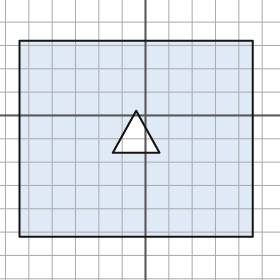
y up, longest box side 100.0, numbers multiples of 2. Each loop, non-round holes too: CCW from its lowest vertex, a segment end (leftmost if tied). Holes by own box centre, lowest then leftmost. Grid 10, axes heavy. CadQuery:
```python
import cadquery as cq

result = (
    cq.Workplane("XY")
    .moveTo(-54.0, -52.0)
    .lineTo(46.0, -52.0)
    .lineTo(46.0, 32.0)
    .lineTo(-54.0, 32.0)
    .close()
    .moveTo(-14.0, -16.0)
    .lineTo(6.0, -16.0)
    .lineTo(-4.0, 2.0)
    .close()
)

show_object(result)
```